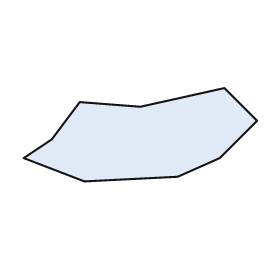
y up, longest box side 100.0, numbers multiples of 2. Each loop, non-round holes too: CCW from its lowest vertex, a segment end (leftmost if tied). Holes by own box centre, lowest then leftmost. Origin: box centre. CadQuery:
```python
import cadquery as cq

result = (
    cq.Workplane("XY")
    .moveTo(-24.0, -20.0)
    .lineTo(16.0, -18.0)
    .lineTo(34.0, -10.0)
    .lineTo(50.0, 6.0)
    .lineTo(36.0, 20.0)
    .lineTo(0.0, 12.0)
    .lineTo(-26.0, 14.0)
    .lineTo(-38.0, -2.0)
    .lineTo(-50.0, -10.0)
    .close()
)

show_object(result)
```